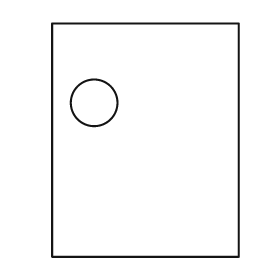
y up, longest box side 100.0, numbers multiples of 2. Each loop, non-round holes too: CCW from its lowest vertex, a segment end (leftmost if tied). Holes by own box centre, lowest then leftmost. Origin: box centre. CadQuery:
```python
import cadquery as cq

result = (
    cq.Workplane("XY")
    .moveTo(-40.0, -50.0)
    .lineTo(40.0, -50.0)
    .lineTo(40.0, 50.0)
    .lineTo(-40.0, 50.0)
    .close()
    .moveTo(-22.0, 16.0)
    .circle(10.0)
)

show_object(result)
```